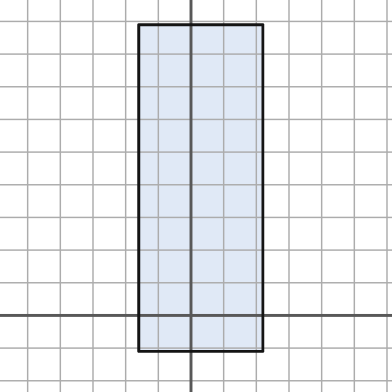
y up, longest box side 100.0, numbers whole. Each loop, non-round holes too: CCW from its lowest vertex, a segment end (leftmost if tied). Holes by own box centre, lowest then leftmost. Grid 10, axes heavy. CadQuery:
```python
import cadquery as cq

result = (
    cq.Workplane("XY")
    .moveTo(-16.0, -11.0)
    .lineTo(22.0, -11.0)
    .lineTo(22.0, 89.0)
    .lineTo(-16.0, 89.0)
    .close()
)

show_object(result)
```